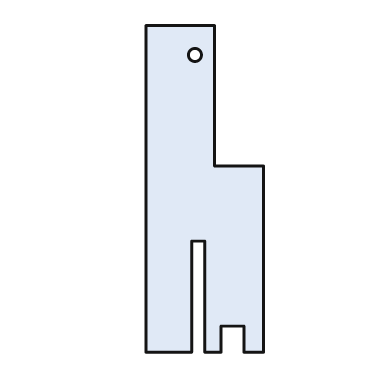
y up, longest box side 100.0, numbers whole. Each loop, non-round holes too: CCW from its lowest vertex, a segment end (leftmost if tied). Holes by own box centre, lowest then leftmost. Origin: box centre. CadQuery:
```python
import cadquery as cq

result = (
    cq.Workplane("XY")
    .moveTo(-18.0, -50.0)
    .lineTo(-4.0, -50.0)
    .lineTo(-4.0, -16.0)
    .lineTo(0.0, -16.0)
    .lineTo(0.0, -50.0)
    .lineTo(5.0, -50.0)
    .lineTo(5.0, -42.0)
    .lineTo(12.0, -42.0)
    .lineTo(12.0, -50.0)
    .lineTo(18.0, -50.0)
    .lineTo(18.0, 7.0)
    .lineTo(3.0, 7.0)
    .lineTo(3.0, 50.0)
    .lineTo(-18.0, 50.0)
    .close()
    .moveTo(-3.0, 41.0)
    .circle(2.0)
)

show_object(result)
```